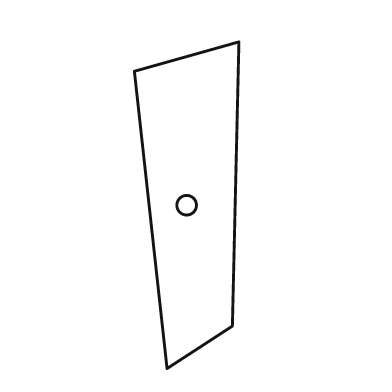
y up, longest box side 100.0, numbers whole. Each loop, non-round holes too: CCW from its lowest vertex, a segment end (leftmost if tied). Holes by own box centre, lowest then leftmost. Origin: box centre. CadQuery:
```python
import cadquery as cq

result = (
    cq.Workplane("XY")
    .moveTo(-6.0, -50.0)
    .lineTo(14.0, -37.0)
    .lineTo(16.0, 50.0)
    .lineTo(-16.0, 41.0)
    .close()
    .moveTo(0.0, 0.0)
    .circle(3.0)
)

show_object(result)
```